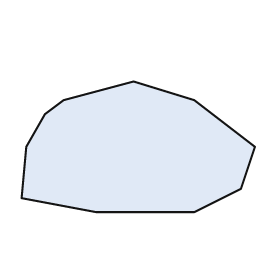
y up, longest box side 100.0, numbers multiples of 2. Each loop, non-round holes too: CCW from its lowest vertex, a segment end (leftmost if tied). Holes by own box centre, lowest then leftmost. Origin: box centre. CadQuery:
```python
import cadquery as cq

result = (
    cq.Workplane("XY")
    .moveTo(-18.0, -28.0)
    .lineTo(24.0, -28.0)
    .lineTo(44.0, -18.0)
    .lineTo(50.0, 0.0)
    .lineTo(24.0, 20.0)
    .lineTo(-2.0, 28.0)
    .lineTo(-32.0, 20.0)
    .lineTo(-40.0, 14.0)
    .lineTo(-48.0, 0.0)
    .lineTo(-50.0, -22.0)
    .close()
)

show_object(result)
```